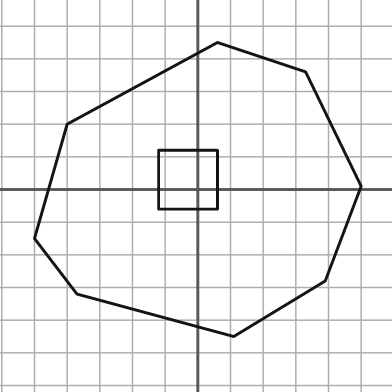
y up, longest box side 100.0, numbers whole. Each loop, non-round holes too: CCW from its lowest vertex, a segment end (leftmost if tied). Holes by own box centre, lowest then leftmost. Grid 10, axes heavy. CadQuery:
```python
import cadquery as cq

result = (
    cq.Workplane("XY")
    .moveTo(11.0, -45.0)
    .lineTo(39.0, -28.0)
    .lineTo(50.0, 1.0)
    .lineTo(33.0, 36.0)
    .lineTo(6.0, 45.0)
    .lineTo(-40.0, 20.0)
    .lineTo(-50.0, -15.0)
    .lineTo(-37.0, -32.0)
    .close()
    .moveTo(-12.0, -6.0)
    .lineTo(6.0, -6.0)
    .lineTo(6.0, 12.0)
    .lineTo(-12.0, 12.0)
    .close()
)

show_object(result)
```